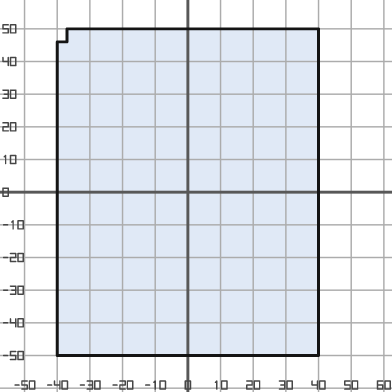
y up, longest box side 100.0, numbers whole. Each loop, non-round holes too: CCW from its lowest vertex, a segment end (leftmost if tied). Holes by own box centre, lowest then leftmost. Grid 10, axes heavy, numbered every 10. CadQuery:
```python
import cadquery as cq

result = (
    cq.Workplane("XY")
    .moveTo(-40.0, -50.0)
    .lineTo(40.0, -50.0)
    .lineTo(40.0, 50.0)
    .lineTo(-37.0, 50.0)
    .lineTo(-37.0, 46.0)
    .lineTo(-40.0, 46.0)
    .close()
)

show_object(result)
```